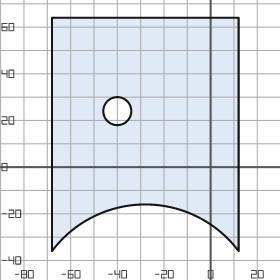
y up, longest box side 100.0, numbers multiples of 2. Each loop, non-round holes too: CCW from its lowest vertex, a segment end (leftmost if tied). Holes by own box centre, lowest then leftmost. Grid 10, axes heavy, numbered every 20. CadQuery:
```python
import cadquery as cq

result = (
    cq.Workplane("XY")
    .moveTo(-68.0, -36.0)
    .threePointArc((-28.0, -16.0), (12.0, -36.0))
    .lineTo(12.0, 64.0)
    .lineTo(-68.0, 64.0)
    .close()
    .moveTo(-40.0, 24.0)
    .circle(6.0)
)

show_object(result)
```